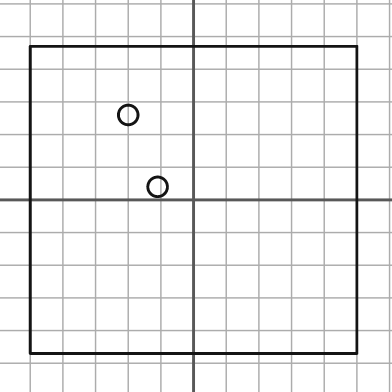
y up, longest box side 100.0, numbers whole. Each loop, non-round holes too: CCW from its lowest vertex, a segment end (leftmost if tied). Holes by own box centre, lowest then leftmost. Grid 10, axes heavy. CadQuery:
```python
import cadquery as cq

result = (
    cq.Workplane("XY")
    .moveTo(-50.0, -47.0)
    .lineTo(50.0, -47.0)
    .lineTo(50.0, 47.0)
    .lineTo(-50.0, 47.0)
    .close()
    .moveTo(-11.0, 4.0)
    .circle(3.0)
    .moveTo(-20.0, 26.0)
    .circle(3.0)
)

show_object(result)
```